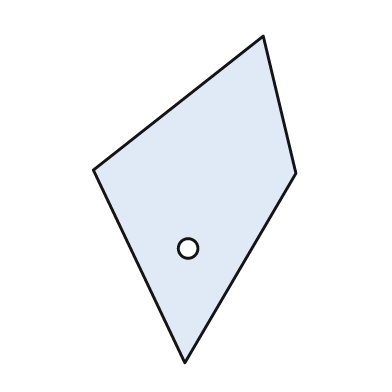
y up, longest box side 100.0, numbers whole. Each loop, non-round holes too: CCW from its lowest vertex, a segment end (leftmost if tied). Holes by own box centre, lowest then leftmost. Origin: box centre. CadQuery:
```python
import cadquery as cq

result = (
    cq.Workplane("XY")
    .moveTo(-3.0, -50.0)
    .lineTo(31.0, 8.0)
    .lineTo(21.0, 50.0)
    .lineTo(-31.0, 9.0)
    .close()
    .moveTo(-2.0, -15.0)
    .circle(3.0)
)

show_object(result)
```